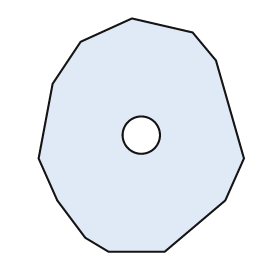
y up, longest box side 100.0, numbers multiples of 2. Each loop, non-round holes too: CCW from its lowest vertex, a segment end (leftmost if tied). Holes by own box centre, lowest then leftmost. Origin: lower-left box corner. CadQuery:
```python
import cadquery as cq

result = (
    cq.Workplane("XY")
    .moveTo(30.0, 0.0)
    .lineTo(54.0, 0.0)
    .lineTo(80.0, 22.0)
    .lineTo(88.0, 40.0)
    .lineTo(76.0, 82.0)
    .lineTo(66.0, 94.0)
    .lineTo(40.0, 100.0)
    .lineTo(18.0, 90.0)
    .lineTo(6.0, 72.0)
    .lineTo(0.0, 40.0)
    .lineTo(8.0, 22.0)
    .lineTo(20.0, 6.0)
    .close()
    .moveTo(44.0, 50.0)
    .circle(8.0)
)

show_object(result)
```